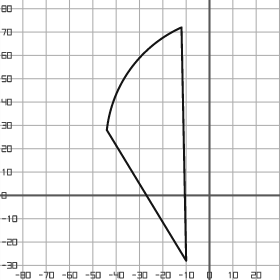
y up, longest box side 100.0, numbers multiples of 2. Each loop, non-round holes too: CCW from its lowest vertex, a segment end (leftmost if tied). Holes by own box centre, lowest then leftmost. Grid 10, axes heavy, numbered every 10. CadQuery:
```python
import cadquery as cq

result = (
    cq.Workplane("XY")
    .moveTo(-10.0, -28.0)
    .lineTo(-12.0, 72.0)
    .threePointArc((-34.0, 54.0), (-44.0, 28.0))
    .close()
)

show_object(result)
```